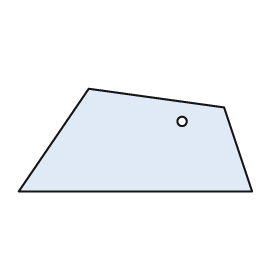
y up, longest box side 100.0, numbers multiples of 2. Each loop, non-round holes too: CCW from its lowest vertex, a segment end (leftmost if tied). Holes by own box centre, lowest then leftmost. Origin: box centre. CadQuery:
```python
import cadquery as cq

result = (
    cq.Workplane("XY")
    .moveTo(-50.0, -22.0)
    .lineTo(50.0, -22.0)
    .lineTo(38.0, 14.0)
    .lineTo(-20.0, 22.0)
    .close()
    .moveTo(20.0, 8.0)
    .circle(2.0)
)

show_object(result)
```